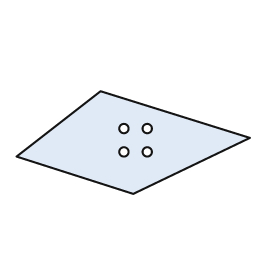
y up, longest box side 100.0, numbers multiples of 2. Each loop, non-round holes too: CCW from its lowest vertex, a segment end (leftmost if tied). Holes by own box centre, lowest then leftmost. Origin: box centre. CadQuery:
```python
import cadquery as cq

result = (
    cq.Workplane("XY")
    .moveTo(0.0, -22.0)
    .lineTo(50.0, 2.0)
    .lineTo(-14.0, 22.0)
    .lineTo(-50.0, -6.0)
    .close()
    .moveTo(-4.0, -4.0)
    .circle(2.0)
    .moveTo(6.0, -4.0)
    .circle(2.0)
    .moveTo(-4.0, 6.0)
    .circle(2.0)
    .moveTo(6.0, 6.0)
    .circle(2.0)
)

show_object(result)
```